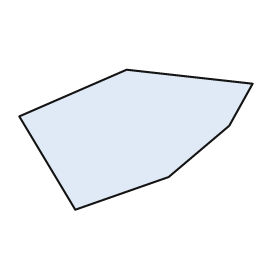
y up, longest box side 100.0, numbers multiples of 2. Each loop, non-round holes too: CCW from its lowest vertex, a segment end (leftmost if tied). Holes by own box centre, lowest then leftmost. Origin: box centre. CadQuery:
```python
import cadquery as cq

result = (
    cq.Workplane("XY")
    .moveTo(-26.0, -30.0)
    .lineTo(14.0, -16.0)
    .lineTo(40.0, 6.0)
    .lineTo(50.0, 24.0)
    .lineTo(-4.0, 30.0)
    .lineTo(-50.0, 10.0)
    .close()
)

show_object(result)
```